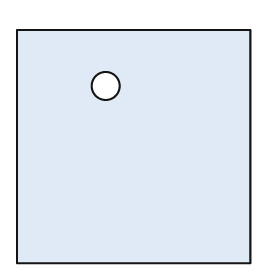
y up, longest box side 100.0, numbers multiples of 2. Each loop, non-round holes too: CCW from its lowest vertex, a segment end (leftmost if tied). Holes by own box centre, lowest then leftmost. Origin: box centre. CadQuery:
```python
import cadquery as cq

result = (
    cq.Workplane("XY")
    .moveTo(-50.0, -50.0)
    .lineTo(50.0, -50.0)
    .lineTo(50.0, 50.0)
    .lineTo(-50.0, 50.0)
    .close()
    .moveTo(-12.0, 26.0)
    .circle(6.0)
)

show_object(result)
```